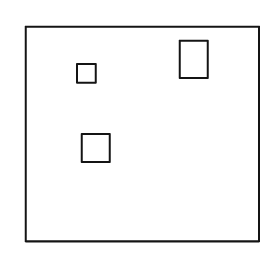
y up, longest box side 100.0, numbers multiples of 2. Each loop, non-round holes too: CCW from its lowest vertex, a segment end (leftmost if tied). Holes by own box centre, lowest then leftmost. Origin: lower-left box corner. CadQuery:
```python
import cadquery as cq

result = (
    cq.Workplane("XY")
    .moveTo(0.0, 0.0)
    .lineTo(100.0, 0.0)
    .lineTo(100.0, 92.0)
    .lineTo(0.0, 92.0)
    .close()
    .moveTo(24.0, 34.0)
    .lineTo(36.0, 34.0)
    .lineTo(36.0, 46.0)
    .lineTo(24.0, 46.0)
    .close()
    .moveTo(22.0, 68.0)
    .lineTo(30.0, 68.0)
    .lineTo(30.0, 76.0)
    .lineTo(22.0, 76.0)
    .close()
    .moveTo(66.0, 70.0)
    .lineTo(78.0, 70.0)
    .lineTo(78.0, 86.0)
    .lineTo(66.0, 86.0)
    .close()
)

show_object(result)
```